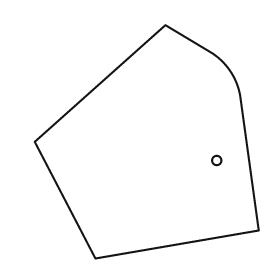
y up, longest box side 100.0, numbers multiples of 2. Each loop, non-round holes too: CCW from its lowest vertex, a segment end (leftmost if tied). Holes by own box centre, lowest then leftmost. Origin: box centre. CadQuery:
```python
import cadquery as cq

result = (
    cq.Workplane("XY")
    .moveTo(-22.0, -50.0)
    .lineTo(48.0, -38.0)
    .lineTo(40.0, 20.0)
    .threePointArc((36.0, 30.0), (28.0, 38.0))
    .lineTo(8.0, 50.0)
    .lineTo(-48.0, 0.0)
    .close()
    .moveTo(30.0, -8.0)
    .circle(2.0)
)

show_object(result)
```